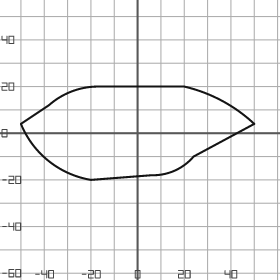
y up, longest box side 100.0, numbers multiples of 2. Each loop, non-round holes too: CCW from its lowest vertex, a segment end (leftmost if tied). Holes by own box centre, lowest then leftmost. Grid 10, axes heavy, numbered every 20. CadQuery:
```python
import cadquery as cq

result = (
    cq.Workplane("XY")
    .moveTo(-20.0, -20.0)
    .lineTo(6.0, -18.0)
    .threePointArc((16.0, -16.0), (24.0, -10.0))
    .lineTo(50.0, 4.0)
    .threePointArc((36.0, 14.0), (20.0, 20.0))
    .lineTo(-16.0, 20.0)
    .threePointArc((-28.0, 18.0), (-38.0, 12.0))
    .lineTo(-50.0, 4.0)
    .threePointArc((-38.0, -12.0), (-20.0, -20.0))
    .close()
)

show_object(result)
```